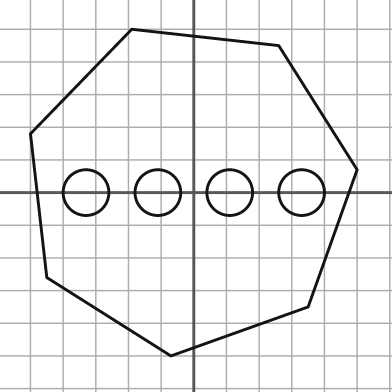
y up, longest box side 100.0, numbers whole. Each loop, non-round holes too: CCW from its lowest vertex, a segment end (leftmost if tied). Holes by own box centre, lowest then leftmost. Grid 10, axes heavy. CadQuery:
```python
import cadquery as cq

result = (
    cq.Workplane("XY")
    .moveTo(-7.0, -50.0)
    .lineTo(35.0, -35.0)
    .lineTo(50.0, 7.0)
    .lineTo(26.0, 45.0)
    .lineTo(-19.0, 50.0)
    .lineTo(-50.0, 18.0)
    .lineTo(-45.0, -26.0)
    .close()
    .moveTo(-33.0, 0.0)
    .circle(7.0)
    .moveTo(-11.0, 0.0)
    .circle(7.0)
    .moveTo(11.0, 0.0)
    .circle(7.0)
    .moveTo(33.0, 0.0)
    .circle(7.0)
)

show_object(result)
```